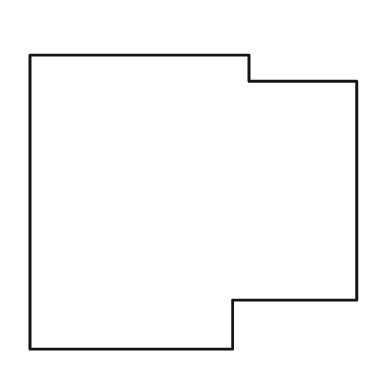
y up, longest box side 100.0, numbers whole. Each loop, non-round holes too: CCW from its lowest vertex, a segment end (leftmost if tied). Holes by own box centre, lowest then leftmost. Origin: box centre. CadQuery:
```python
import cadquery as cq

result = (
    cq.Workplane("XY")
    .moveTo(-50.0, -45.0)
    .lineTo(12.0, -45.0)
    .lineTo(12.0, -30.0)
    .lineTo(50.0, -30.0)
    .lineTo(50.0, 37.0)
    .lineTo(17.0, 37.0)
    .lineTo(17.0, 45.0)
    .lineTo(-50.0, 45.0)
    .close()
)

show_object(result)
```